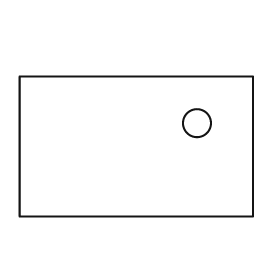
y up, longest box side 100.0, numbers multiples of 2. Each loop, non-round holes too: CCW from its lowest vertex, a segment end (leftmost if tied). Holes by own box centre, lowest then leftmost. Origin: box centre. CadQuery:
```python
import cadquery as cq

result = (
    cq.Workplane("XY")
    .moveTo(-50.0, -30.0)
    .lineTo(50.0, -30.0)
    .lineTo(50.0, 30.0)
    .lineTo(-50.0, 30.0)
    .close()
    .moveTo(26.0, 10.0)
    .circle(6.0)
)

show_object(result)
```